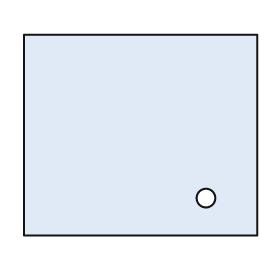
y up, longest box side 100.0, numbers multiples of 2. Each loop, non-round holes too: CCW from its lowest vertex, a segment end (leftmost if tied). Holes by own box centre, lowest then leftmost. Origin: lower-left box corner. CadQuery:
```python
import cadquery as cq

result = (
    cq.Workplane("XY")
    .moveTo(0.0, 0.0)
    .lineTo(100.0, 0.0)
    .lineTo(100.0, 86.0)
    .lineTo(0.0, 86.0)
    .close()
    .moveTo(78.0, 16.0)
    .circle(4.0)
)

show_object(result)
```